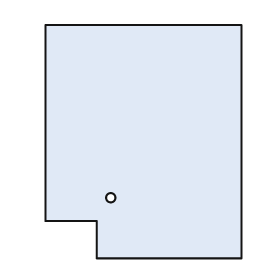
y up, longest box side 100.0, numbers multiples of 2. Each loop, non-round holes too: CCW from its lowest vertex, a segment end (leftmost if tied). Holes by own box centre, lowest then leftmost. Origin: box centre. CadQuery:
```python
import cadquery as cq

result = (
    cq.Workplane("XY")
    .moveTo(-20.0, -50.0)
    .lineTo(42.0, -50.0)
    .lineTo(42.0, 50.0)
    .lineTo(-42.0, 50.0)
    .lineTo(-42.0, -34.0)
    .lineTo(-20.0, -34.0)
    .close()
    .moveTo(-14.0, -24.0)
    .circle(2.0)
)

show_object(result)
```